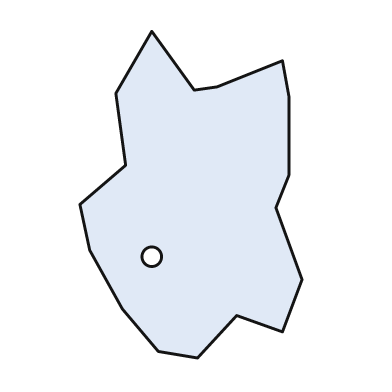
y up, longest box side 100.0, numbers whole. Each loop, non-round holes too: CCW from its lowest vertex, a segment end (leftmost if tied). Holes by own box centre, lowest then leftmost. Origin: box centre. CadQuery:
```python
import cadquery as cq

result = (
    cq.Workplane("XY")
    .moveTo(2.0, -50.0)
    .lineTo(14.0, -37.0)
    .lineTo(28.0, -42.0)
    .lineTo(34.0, -26.0)
    .lineTo(26.0, -4.0)
    .lineTo(30.0, 6.0)
    .lineTo(30.0, 30.0)
    .lineTo(28.0, 41.0)
    .lineTo(8.0, 33.0)
    .lineTo(1.0, 32.0)
    .lineTo(-12.0, 50.0)
    .lineTo(-23.0, 31.0)
    .lineTo(-20.0, 9.0)
    .lineTo(-34.0, -3.0)
    .lineTo(-31.0, -17.0)
    .lineTo(-21.0, -35.0)
    .lineTo(-10.0, -48.0)
    .close()
    .moveTo(-12.0, -19.0)
    .circle(3.0)
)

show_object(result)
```